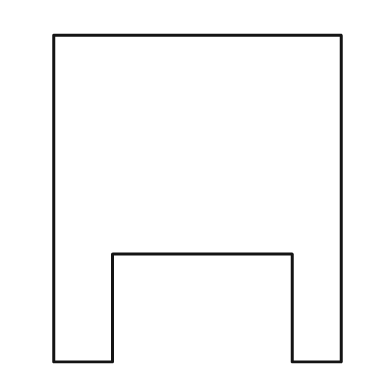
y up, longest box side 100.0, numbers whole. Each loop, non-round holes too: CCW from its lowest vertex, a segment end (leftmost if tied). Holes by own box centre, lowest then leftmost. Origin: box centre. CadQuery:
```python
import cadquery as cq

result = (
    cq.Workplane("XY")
    .moveTo(-44.0, -50.0)
    .lineTo(-26.0, -50.0)
    .lineTo(-26.0, -17.0)
    .lineTo(29.0, -17.0)
    .lineTo(29.0, -50.0)
    .lineTo(44.0, -50.0)
    .lineTo(44.0, 50.0)
    .lineTo(-44.0, 50.0)
    .close()
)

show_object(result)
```